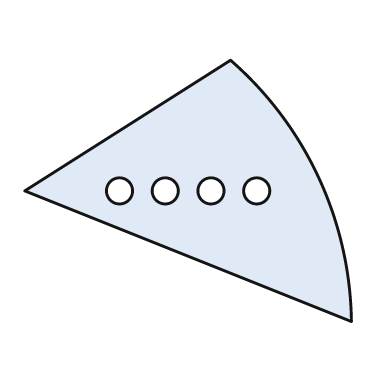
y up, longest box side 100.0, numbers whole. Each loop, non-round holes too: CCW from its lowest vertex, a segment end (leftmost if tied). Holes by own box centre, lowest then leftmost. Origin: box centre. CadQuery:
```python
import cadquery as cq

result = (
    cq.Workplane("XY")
    .moveTo(50.0, -40.0)
    .threePointArc((40.0, 4.0), (13.0, 40.0))
    .lineTo(-50.0, 0.0)
    .close()
    .moveTo(-21.0, 0.0)
    .circle(4.0)
    .moveTo(-7.0, 0.0)
    .circle(4.0)
    .moveTo(7.0, 0.0)
    .circle(4.0)
    .moveTo(21.0, 0.0)
    .circle(4.0)
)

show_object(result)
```